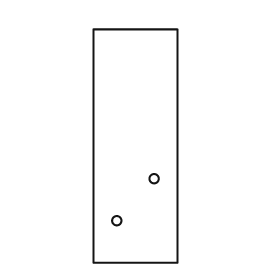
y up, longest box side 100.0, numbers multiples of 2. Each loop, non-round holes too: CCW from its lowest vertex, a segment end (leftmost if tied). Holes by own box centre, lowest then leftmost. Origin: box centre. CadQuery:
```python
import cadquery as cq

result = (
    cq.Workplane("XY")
    .moveTo(-18.0, -50.0)
    .lineTo(18.0, -50.0)
    .lineTo(18.0, 50.0)
    .lineTo(-18.0, 50.0)
    .close()
    .moveTo(-8.0, -32.0)
    .circle(2.0)
    .moveTo(8.0, -14.0)
    .circle(2.0)
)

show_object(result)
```